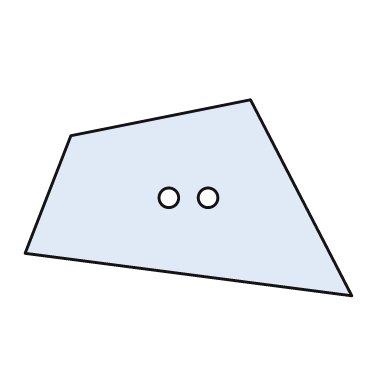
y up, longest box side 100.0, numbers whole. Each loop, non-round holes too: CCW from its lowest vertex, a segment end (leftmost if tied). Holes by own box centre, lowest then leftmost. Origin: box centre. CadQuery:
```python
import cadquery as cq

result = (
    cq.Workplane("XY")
    .moveTo(50.0, -30.0)
    .lineTo(19.0, 30.0)
    .lineTo(-36.0, 19.0)
    .lineTo(-50.0, -17.0)
    .close()
    .moveTo(-6.0, 0.0)
    .circle(3.0)
    .moveTo(6.0, 0.0)
    .circle(3.0)
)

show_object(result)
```